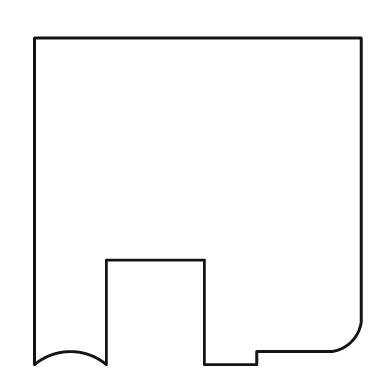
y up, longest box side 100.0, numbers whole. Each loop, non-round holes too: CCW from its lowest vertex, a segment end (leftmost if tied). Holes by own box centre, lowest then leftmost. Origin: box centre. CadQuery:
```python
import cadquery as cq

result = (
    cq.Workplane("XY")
    .moveTo(-50.0, -50.0)
    .threePointArc((-39.0, -46.0), (-28.0, -50.0))
    .lineTo(-28.0, -18.0)
    .lineTo(2.0, -18.0)
    .lineTo(2.0, -50.0)
    .lineTo(18.0, -50.0)
    .lineTo(18.0, -46.0)
    .lineTo(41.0, -46.0)
    .threePointArc((47.0, -43.0), (50.0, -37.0))
    .lineTo(50.0, 50.0)
    .lineTo(-50.0, 50.0)
    .close()
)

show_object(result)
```